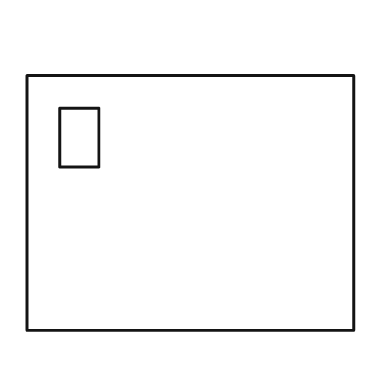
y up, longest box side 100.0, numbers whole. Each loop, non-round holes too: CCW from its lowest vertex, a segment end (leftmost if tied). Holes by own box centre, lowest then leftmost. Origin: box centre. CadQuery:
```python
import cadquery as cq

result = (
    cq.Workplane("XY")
    .moveTo(-50.0, -39.0)
    .lineTo(50.0, -39.0)
    .lineTo(50.0, 39.0)
    .lineTo(-50.0, 39.0)
    .close()
    .moveTo(-40.0, 11.0)
    .lineTo(-28.0, 11.0)
    .lineTo(-28.0, 29.0)
    .lineTo(-40.0, 29.0)
    .close()
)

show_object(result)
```